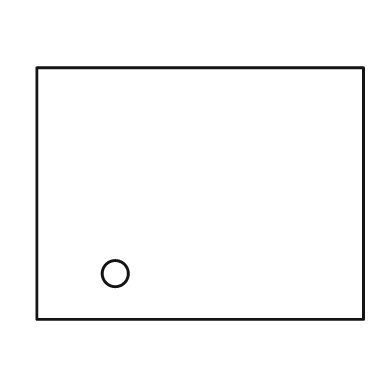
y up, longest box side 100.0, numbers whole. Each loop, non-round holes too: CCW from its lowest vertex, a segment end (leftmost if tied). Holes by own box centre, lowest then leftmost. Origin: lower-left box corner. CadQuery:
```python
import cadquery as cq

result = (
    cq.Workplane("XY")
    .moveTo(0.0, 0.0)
    .lineTo(100.0, 0.0)
    .lineTo(100.0, 77.0)
    .lineTo(0.0, 77.0)
    .close()
    .moveTo(24.0, 14.0)
    .circle(4.0)
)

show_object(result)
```